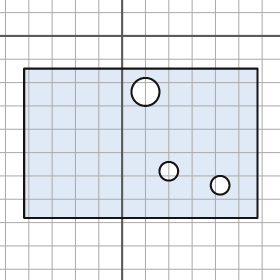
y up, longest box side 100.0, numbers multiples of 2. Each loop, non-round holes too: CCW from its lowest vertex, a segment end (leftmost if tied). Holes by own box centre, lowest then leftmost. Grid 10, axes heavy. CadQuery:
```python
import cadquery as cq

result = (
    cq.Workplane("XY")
    .moveTo(-42.0, -78.0)
    .lineTo(58.0, -78.0)
    .lineTo(58.0, -14.0)
    .lineTo(-42.0, -14.0)
    .close()
    .moveTo(42.0, -64.0)
    .circle(4.0)
    .moveTo(20.0, -58.0)
    .circle(4.0)
    .moveTo(10.0, -24.0)
    .circle(6.0)
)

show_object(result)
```